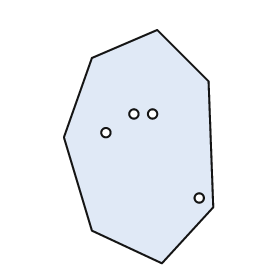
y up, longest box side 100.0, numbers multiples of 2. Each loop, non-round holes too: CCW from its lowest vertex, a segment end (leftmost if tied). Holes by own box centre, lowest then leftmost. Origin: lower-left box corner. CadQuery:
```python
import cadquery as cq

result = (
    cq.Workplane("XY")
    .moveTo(42.0, 0.0)
    .lineTo(64.0, 24.0)
    .lineTo(62.0, 78.0)
    .lineTo(40.0, 100.0)
    .lineTo(12.0, 88.0)
    .lineTo(0.0, 54.0)
    .lineTo(12.0, 14.0)
    .close()
    .moveTo(58.0, 28.0)
    .circle(2.0)
    .moveTo(18.0, 56.0)
    .circle(2.0)
    .moveTo(30.0, 64.0)
    .circle(2.0)
    .moveTo(38.0, 64.0)
    .circle(2.0)
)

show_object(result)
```